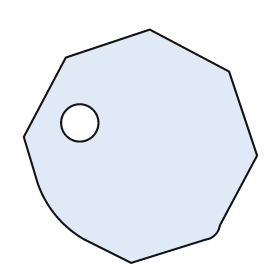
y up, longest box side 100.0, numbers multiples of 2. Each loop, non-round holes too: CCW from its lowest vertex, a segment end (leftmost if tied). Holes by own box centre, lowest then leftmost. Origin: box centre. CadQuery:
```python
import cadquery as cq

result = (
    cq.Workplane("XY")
    .moveTo(-4.0, -50.0)
    .lineTo(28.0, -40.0)
    .threePointArc((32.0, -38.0), (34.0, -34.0))
    .lineTo(50.0, -4.0)
    .lineTo(38.0, 32.0)
    .lineTo(4.0, 50.0)
    .lineTo(-32.0, 38.0)
    .lineTo(-50.0, 4.0)
    .lineTo(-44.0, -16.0)
    .threePointArc((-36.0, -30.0), (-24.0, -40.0))
    .close()
    .moveTo(-26.0, 10.0)
    .circle(8.0)
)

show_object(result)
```